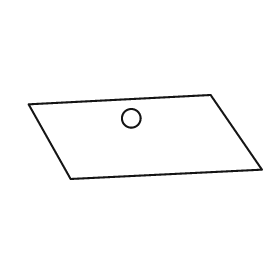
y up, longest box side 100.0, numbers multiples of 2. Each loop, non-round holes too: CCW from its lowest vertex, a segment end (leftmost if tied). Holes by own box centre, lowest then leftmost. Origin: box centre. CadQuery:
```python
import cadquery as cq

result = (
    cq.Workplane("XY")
    .moveTo(-32.0, -18.0)
    .lineTo(50.0, -14.0)
    .lineTo(28.0, 18.0)
    .lineTo(-50.0, 14.0)
    .close()
    .moveTo(-6.0, 8.0)
    .circle(4.0)
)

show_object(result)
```